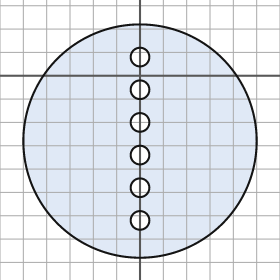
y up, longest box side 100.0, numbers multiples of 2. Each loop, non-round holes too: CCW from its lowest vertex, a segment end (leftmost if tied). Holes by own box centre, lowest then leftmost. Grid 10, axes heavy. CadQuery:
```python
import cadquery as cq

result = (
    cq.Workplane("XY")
    .moveTo(0.0, -28.0)
    .circle(50.0)
    .moveTo(0.0, -62.0)
    .circle(4.0)
    .moveTo(0.0, -48.0)
    .circle(4.0)
    .moveTo(0.0, -34.0)
    .circle(4.0)
    .moveTo(0.0, -20.0)
    .circle(4.0)
    .moveTo(0.0, -6.0)
    .circle(4.0)
    .moveTo(0.0, 8.0)
    .circle(4.0)
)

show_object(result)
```